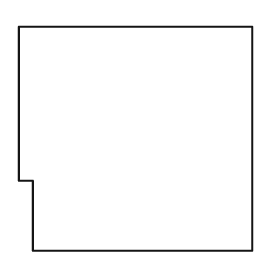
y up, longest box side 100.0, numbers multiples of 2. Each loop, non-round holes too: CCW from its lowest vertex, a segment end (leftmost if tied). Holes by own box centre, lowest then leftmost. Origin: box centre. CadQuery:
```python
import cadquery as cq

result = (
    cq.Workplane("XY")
    .moveTo(-44.0, -48.0)
    .lineTo(50.0, -48.0)
    .lineTo(50.0, 48.0)
    .lineTo(-50.0, 48.0)
    .lineTo(-50.0, -18.0)
    .lineTo(-44.0, -18.0)
    .close()
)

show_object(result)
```